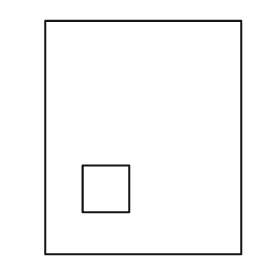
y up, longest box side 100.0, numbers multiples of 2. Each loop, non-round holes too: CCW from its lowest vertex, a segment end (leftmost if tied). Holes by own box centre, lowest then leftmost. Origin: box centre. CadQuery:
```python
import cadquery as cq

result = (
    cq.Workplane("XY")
    .moveTo(-42.0, -50.0)
    .lineTo(42.0, -50.0)
    .lineTo(42.0, 50.0)
    .lineTo(-42.0, 50.0)
    .close()
    .moveTo(-26.0, -32.0)
    .lineTo(-6.0, -32.0)
    .lineTo(-6.0, -12.0)
    .lineTo(-26.0, -12.0)
    .close()
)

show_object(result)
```